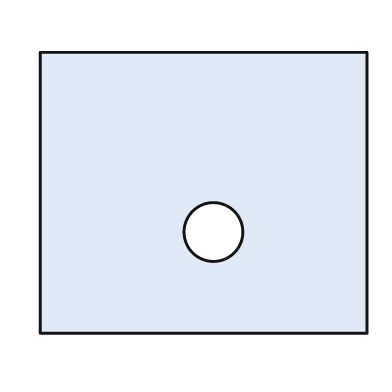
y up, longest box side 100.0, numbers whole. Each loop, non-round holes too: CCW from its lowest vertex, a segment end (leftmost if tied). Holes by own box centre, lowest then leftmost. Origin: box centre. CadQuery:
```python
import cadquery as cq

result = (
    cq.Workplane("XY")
    .moveTo(-50.0, -43.0)
    .lineTo(50.0, -43.0)
    .lineTo(50.0, 43.0)
    .lineTo(-50.0, 43.0)
    .close()
    .moveTo(3.0, -12.0)
    .circle(9.0)
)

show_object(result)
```